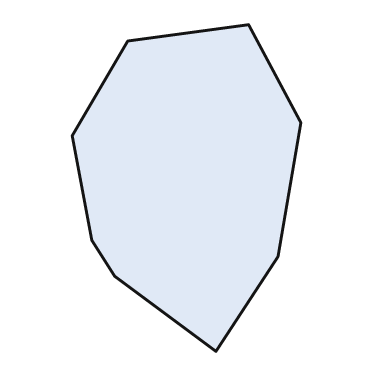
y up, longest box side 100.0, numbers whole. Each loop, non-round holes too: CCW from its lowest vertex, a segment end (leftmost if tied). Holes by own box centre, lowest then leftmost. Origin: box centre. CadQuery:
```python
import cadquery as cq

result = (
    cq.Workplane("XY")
    .moveTo(9.0, -50.0)
    .lineTo(28.0, -21.0)
    .lineTo(35.0, 20.0)
    .lineTo(19.0, 50.0)
    .lineTo(-18.0, 45.0)
    .lineTo(-35.0, 16.0)
    .lineTo(-29.0, -16.0)
    .lineTo(-22.0, -27.0)
    .close()
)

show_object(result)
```